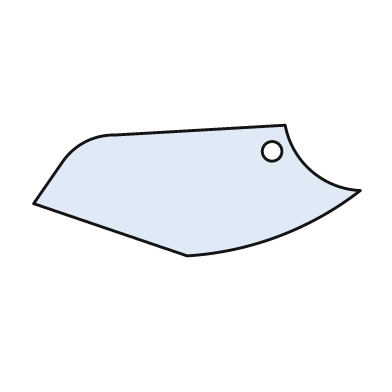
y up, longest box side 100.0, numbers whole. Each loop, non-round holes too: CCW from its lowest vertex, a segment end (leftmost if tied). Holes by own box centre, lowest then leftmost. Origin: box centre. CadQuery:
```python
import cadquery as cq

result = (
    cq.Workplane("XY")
    .moveTo(-3.0, -20.0)
    .threePointArc((25.0, -14.0), (50.0, 0.0))
    .threePointArc((35.0, 6.0), (27.0, 20.0))
    .lineTo(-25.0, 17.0)
    .threePointArc((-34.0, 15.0), (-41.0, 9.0))
    .lineTo(-50.0, -4.0)
    .close()
    .moveTo(23.0, 12.0)
    .circle(3.0)
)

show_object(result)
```